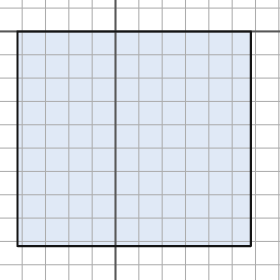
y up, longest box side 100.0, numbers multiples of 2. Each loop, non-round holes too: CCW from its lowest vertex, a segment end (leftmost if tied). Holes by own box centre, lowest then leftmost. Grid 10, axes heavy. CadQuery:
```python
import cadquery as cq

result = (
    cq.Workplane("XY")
    .moveTo(-42.0, -92.0)
    .lineTo(58.0, -92.0)
    .lineTo(58.0, 0.0)
    .lineTo(-42.0, 0.0)
    .close()
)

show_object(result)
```